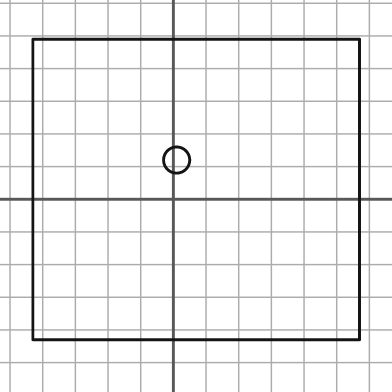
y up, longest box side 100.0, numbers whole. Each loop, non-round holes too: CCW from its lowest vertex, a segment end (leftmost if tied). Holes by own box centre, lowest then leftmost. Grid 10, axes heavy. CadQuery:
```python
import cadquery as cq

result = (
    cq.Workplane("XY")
    .moveTo(-43.0, -43.0)
    .lineTo(57.0, -43.0)
    .lineTo(57.0, 49.0)
    .lineTo(-43.0, 49.0)
    .close()
    .moveTo(1.0, 12.0)
    .circle(4.0)
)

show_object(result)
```